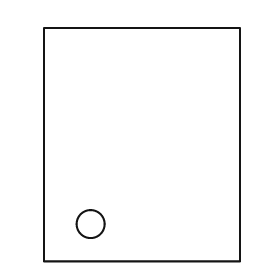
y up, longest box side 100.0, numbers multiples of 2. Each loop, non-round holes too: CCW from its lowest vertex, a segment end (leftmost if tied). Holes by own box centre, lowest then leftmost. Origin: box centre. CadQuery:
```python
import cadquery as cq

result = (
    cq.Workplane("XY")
    .moveTo(-42.0, -50.0)
    .lineTo(42.0, -50.0)
    .lineTo(42.0, 50.0)
    .lineTo(-42.0, 50.0)
    .close()
    .moveTo(-22.0, -34.0)
    .circle(6.0)
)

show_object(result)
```